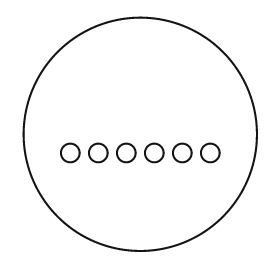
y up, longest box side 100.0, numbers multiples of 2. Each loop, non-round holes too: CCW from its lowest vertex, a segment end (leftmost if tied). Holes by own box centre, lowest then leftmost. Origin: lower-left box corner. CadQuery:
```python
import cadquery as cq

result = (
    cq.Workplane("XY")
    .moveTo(50.0, 50.0)
    .circle(50.0)
    .moveTo(20.0, 42.0)
    .circle(4.0)
    .moveTo(32.0, 42.0)
    .circle(4.0)
    .moveTo(44.0, 42.0)
    .circle(4.0)
    .moveTo(56.0, 42.0)
    .circle(4.0)
    .moveTo(68.0, 42.0)
    .circle(4.0)
    .moveTo(80.0, 42.0)
    .circle(4.0)
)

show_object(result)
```